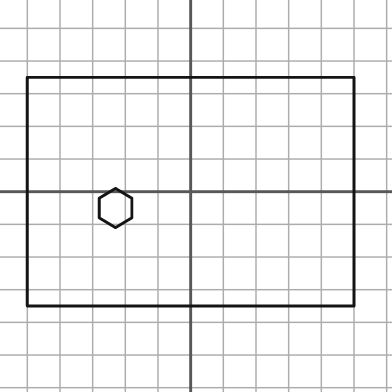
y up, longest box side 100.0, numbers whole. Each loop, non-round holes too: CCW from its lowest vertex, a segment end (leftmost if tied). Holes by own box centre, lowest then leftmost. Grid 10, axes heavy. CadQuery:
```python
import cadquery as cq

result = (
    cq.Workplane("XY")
    .moveTo(-50.0, -35.0)
    .lineTo(50.0, -35.0)
    .lineTo(50.0, 35.0)
    .lineTo(-50.0, 35.0)
    .close()
    .moveTo(-23.0, -11.0)
    .lineTo(-18.0, -8.0)
    .lineTo(-18.0, -2.0)
    .lineTo(-23.0, 1.0)
    .lineTo(-28.0, -2.0)
    .lineTo(-28.0, -8.0)
    .close()
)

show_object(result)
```